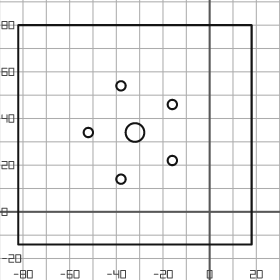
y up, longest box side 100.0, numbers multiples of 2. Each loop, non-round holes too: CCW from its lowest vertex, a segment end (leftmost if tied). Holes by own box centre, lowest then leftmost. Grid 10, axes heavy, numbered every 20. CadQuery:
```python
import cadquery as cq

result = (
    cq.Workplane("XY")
    .moveTo(-82.0, -14.0)
    .lineTo(18.0, -14.0)
    .lineTo(18.0, 80.0)
    .lineTo(-82.0, 80.0)
    .close()
    .moveTo(-38.0, 14.0)
    .circle(2.0)
    .moveTo(-16.0, 22.0)
    .circle(2.0)
    .moveTo(-52.0, 34.0)
    .circle(2.0)
    .moveTo(-32.0, 34.0)
    .circle(4.0)
    .moveTo(-16.0, 46.0)
    .circle(2.0)
    .moveTo(-38.0, 54.0)
    .circle(2.0)
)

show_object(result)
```